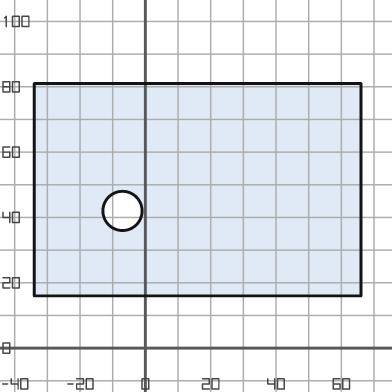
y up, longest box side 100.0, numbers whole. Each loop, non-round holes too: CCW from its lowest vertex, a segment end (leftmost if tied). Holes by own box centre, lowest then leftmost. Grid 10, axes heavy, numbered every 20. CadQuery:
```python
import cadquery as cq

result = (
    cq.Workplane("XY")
    .moveTo(-34.0, 16.0)
    .lineTo(66.0, 16.0)
    .lineTo(66.0, 81.0)
    .lineTo(-34.0, 81.0)
    .close()
    .moveTo(-7.0, 42.0)
    .circle(6.0)
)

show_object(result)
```